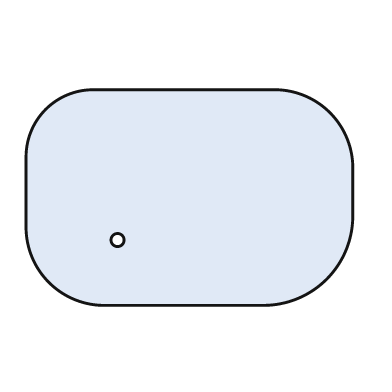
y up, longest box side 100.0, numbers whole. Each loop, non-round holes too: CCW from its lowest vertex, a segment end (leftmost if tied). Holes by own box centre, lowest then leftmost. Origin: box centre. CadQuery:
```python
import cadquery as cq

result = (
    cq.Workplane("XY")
    .moveTo(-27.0, -33.0)
    .lineTo(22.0, -33.0)
    .threePointArc((42.0, -25.0), (50.0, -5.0))
    .lineTo(50.0, 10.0)
    .threePointArc((43.0, 26.0), (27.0, 33.0))
    .lineTo(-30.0, 33.0)
    .threePointArc((-44.0, 27.0), (-50.0, 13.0))
    .lineTo(-50.0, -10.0)
    .threePointArc((-43.0, -26.0), (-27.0, -33.0))
    .close()
    .moveTo(-22.0, -13.0)
    .circle(2.0)
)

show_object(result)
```